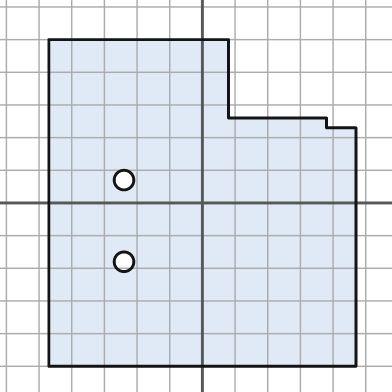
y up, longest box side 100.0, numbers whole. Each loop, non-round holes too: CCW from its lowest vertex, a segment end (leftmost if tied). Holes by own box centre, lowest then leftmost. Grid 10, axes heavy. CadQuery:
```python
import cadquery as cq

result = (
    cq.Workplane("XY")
    .moveTo(-47.0, -50.0)
    .lineTo(47.0, -50.0)
    .lineTo(47.0, 23.0)
    .lineTo(38.0, 23.0)
    .lineTo(38.0, 26.0)
    .lineTo(8.0, 26.0)
    .lineTo(8.0, 50.0)
    .lineTo(-47.0, 50.0)
    .close()
    .moveTo(-24.0, -18.0)
    .circle(3.0)
    .moveTo(-24.0, 7.0)
    .circle(3.0)
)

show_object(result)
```